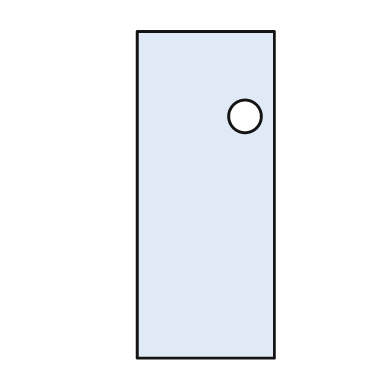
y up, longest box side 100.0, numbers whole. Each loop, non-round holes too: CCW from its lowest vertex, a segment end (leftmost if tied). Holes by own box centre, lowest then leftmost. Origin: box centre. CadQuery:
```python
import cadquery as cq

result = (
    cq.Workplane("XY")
    .moveTo(-21.0, -50.0)
    .lineTo(21.0, -50.0)
    .lineTo(21.0, 50.0)
    .lineTo(-21.0, 50.0)
    .close()
    .moveTo(12.0, 24.0)
    .circle(5.0)
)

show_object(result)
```